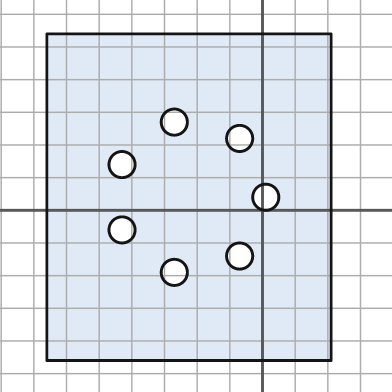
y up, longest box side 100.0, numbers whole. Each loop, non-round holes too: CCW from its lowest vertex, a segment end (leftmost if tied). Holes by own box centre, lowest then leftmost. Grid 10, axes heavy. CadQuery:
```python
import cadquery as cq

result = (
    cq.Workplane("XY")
    .moveTo(-66.0, -46.0)
    .lineTo(21.0, -46.0)
    .lineTo(21.0, 54.0)
    .lineTo(-66.0, 54.0)
    .close()
    .moveTo(-27.0, -19.0)
    .circle(4.0)
    .moveTo(-7.0, -14.0)
    .circle(4.0)
    .moveTo(-43.0, -6.0)
    .circle(4.0)
    .moveTo(1.0, 4.0)
    .circle(4.0)
    .moveTo(-43.0, 14.0)
    .circle(4.0)
    .moveTo(-7.0, 22.0)
    .circle(4.0)
    .moveTo(-27.0, 27.0)
    .circle(4.0)
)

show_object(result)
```